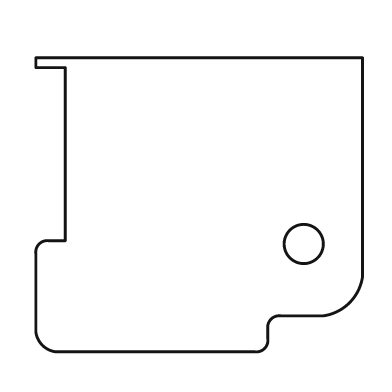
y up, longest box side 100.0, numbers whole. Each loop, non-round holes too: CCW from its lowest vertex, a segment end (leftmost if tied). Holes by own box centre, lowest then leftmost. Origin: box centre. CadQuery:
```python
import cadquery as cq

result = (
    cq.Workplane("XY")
    .moveTo(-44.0, -45.0)
    .lineTo(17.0, -45.0)
    .threePointArc((20.0, -44.0), (21.0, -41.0))
    .lineTo(21.0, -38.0)
    .threePointArc((22.0, -35.0), (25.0, -34.0))
    .lineTo(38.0, -34.0)
    .threePointArc((46.0, -30.0), (50.0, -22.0))
    .lineTo(50.0, 45.0)
    .lineTo(-50.0, 45.0)
    .lineTo(-50.0, 42.0)
    .lineTo(-41.0, 42.0)
    .lineTo(-41.0, -11.0)
    .lineTo(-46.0, -11.0)
    .threePointArc((-49.0, -12.0), (-50.0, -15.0))
    .lineTo(-50.0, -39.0)
    .threePointArc((-48.0, -43.0), (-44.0, -45.0))
    .close()
    .moveTo(32.0, -12.0)
    .circle(6.0)
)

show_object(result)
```